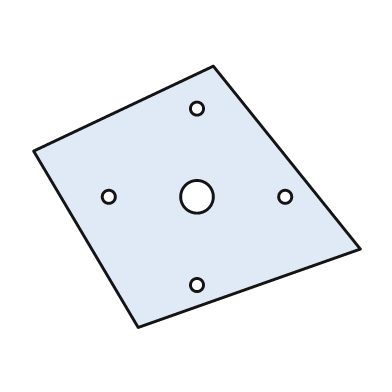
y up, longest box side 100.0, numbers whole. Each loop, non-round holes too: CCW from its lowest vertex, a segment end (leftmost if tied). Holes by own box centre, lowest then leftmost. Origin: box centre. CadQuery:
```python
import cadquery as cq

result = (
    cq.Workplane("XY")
    .moveTo(-18.0, -40.0)
    .lineTo(50.0, -16.0)
    .lineTo(5.0, 40.0)
    .lineTo(-50.0, 14.0)
    .close()
    .moveTo(0.0, -27.0)
    .circle(2.0)
    .moveTo(-27.0, 0.0)
    .circle(2.0)
    .moveTo(0.0, 0.0)
    .circle(5.0)
    .moveTo(27.0, 0.0)
    .circle(2.0)
    .moveTo(0.0, 27.0)
    .circle(2.0)
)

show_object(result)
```